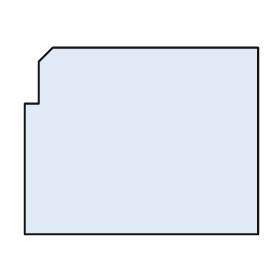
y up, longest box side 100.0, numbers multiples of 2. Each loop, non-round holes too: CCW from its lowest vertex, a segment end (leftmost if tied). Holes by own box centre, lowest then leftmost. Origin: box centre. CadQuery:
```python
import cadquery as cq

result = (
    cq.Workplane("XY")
    .moveTo(-50.0, -40.0)
    .lineTo(50.0, -40.0)
    .lineTo(50.0, 40.0)
    .lineTo(-38.0, 40.0)
    .lineTo(-44.0, 34.0)
    .lineTo(-44.0, 16.0)
    .lineTo(-50.0, 16.0)
    .close()
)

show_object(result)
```